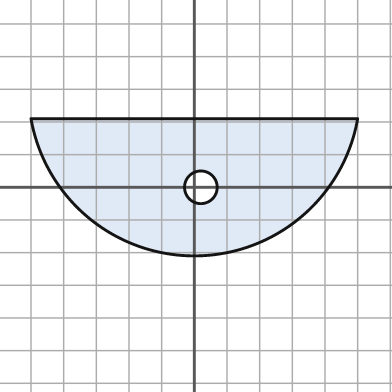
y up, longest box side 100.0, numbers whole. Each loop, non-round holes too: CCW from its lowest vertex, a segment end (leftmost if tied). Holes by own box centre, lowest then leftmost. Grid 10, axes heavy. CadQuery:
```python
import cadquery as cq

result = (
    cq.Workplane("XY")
    .moveTo(-50.0, 21.0)
    .threePointArc((0.0, -21.0), (50.0, 21.0))
    .close()
    .moveTo(2.0, 0.0)
    .circle(5.0)
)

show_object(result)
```